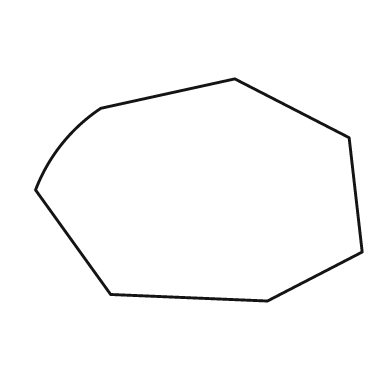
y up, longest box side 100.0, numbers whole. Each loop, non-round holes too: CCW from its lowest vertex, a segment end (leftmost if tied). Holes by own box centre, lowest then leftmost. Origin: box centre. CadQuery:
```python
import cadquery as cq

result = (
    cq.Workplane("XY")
    .moveTo(21.0, -34.0)
    .lineTo(50.0, -19.0)
    .lineTo(46.0, 16.0)
    .lineTo(11.0, 34.0)
    .lineTo(-30.0, 25.0)
    .threePointArc((-42.0, 14.0), (-50.0, 0.0))
    .lineTo(-27.0, -32.0)
    .close()
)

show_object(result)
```